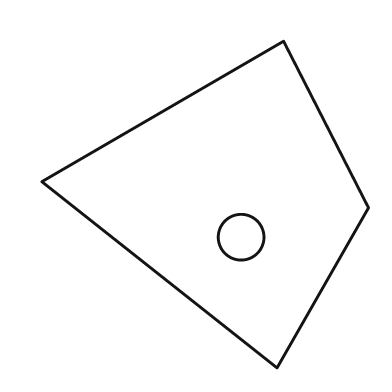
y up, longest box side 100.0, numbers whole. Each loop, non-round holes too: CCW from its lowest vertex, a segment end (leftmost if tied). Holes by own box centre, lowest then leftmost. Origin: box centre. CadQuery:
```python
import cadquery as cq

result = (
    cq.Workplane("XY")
    .moveTo(22.0, -50.0)
    .lineTo(50.0, -1.0)
    .lineTo(24.0, 50.0)
    .lineTo(-50.0, 7.0)
    .close()
    .moveTo(11.0, -10.0)
    .circle(7.0)
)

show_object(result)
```